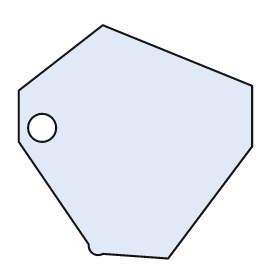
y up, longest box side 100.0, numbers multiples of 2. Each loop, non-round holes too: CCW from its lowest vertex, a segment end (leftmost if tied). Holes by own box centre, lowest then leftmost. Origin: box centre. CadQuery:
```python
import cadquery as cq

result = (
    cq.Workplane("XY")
    .moveTo(14.0, -50.0)
    .lineTo(50.0, -2.0)
    .lineTo(50.0, 24.0)
    .lineTo(-14.0, 50.0)
    .lineTo(-50.0, 22.0)
    .lineTo(-50.0, 0.0)
    .lineTo(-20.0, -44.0)
    .threePointArc((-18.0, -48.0), (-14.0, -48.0))
    .close()
    .moveTo(-40.0, 6.0)
    .circle(6.0)
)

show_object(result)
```